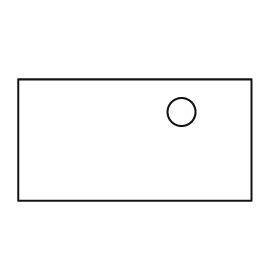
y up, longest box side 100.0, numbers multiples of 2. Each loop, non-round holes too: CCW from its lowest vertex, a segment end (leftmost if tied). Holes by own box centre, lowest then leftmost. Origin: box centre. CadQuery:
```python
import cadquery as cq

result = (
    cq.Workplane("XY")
    .moveTo(-50.0, -26.0)
    .lineTo(50.0, -26.0)
    .lineTo(50.0, 26.0)
    .lineTo(-50.0, 26.0)
    .close()
    .moveTo(20.0, 12.0)
    .circle(6.0)
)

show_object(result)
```